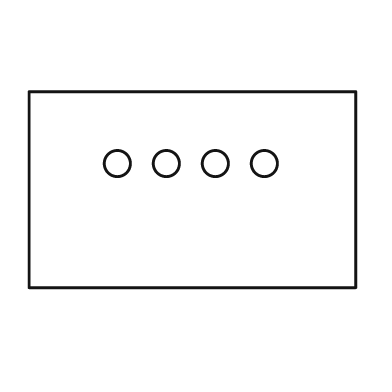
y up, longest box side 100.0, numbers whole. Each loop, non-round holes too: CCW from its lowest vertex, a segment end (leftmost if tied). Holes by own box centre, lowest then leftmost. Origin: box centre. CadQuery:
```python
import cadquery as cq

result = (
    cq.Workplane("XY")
    .moveTo(-50.0, -30.0)
    .lineTo(50.0, -30.0)
    .lineTo(50.0, 30.0)
    .lineTo(-50.0, 30.0)
    .close()
    .moveTo(-23.0, 8.0)
    .circle(4.0)
    .moveTo(-8.0, 8.0)
    .circle(4.0)
    .moveTo(7.0, 8.0)
    .circle(4.0)
    .moveTo(22.0, 8.0)
    .circle(4.0)
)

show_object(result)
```